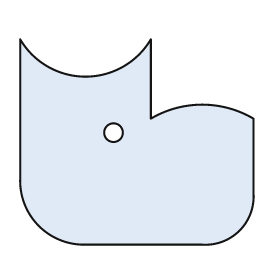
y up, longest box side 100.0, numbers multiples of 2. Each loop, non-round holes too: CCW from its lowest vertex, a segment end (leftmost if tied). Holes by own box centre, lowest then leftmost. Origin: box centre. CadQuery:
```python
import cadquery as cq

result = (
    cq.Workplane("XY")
    .moveTo(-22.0, -44.0)
    .lineTo(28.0, -44.0)
    .threePointArc((44.0, -38.0), (50.0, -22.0))
    .lineTo(50.0, 10.0)
    .threePointArc((28.0, 16.0), (6.0, 10.0))
    .lineTo(6.0, 44.0)
    .threePointArc((-22.0, 28.0), (-50.0, 44.0))
    .lineTo(-50.0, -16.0)
    .threePointArc((-42.0, -36.0), (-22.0, -44.0))
    .close()
    .moveTo(-10.0, 4.0)
    .circle(4.0)
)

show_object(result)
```